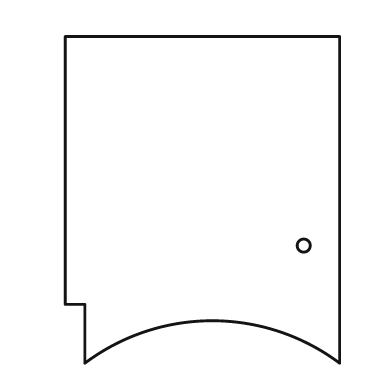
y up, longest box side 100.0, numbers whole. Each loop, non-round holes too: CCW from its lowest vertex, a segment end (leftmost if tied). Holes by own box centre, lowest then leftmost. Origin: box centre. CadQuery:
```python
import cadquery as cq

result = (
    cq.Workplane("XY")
    .moveTo(-36.0, -50.0)
    .threePointArc((3.0, -37.0), (42.0, -50.0))
    .lineTo(42.0, 50.0)
    .lineTo(-42.0, 50.0)
    .lineTo(-42.0, -32.0)
    .lineTo(-36.0, -32.0)
    .close()
    .moveTo(31.0, -14.0)
    .circle(2.0)
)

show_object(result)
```